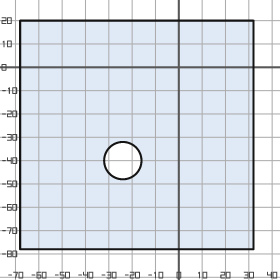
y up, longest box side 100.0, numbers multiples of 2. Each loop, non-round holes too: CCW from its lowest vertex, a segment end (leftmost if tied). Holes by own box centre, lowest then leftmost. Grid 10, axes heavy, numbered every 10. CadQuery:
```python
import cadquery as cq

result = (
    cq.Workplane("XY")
    .moveTo(-68.0, -78.0)
    .lineTo(32.0, -78.0)
    .lineTo(32.0, 20.0)
    .lineTo(-68.0, 20.0)
    .close()
    .moveTo(-24.0, -40.0)
    .circle(8.0)
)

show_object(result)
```